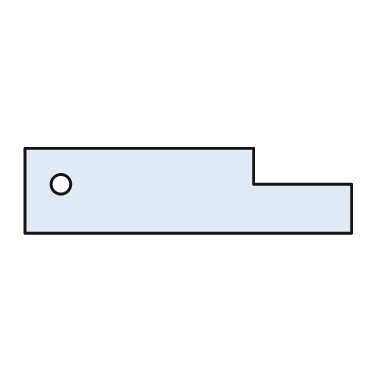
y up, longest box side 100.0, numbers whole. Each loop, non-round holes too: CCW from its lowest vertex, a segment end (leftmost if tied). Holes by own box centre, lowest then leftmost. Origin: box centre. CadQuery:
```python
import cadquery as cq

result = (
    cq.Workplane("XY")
    .moveTo(-50.0, -13.0)
    .lineTo(50.0, -13.0)
    .lineTo(50.0, 2.0)
    .lineTo(20.0, 2.0)
    .lineTo(20.0, 13.0)
    .lineTo(-50.0, 13.0)
    .close()
    .moveTo(-39.0, 2.0)
    .circle(3.0)
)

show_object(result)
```